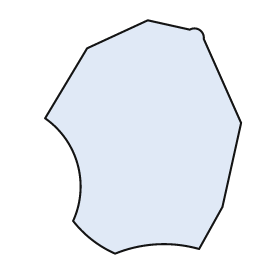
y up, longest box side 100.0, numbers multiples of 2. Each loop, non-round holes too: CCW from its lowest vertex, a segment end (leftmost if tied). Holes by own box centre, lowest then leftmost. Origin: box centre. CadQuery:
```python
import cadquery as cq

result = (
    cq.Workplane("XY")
    .moveTo(-12.0, -50.0)
    .threePointArc((6.0, -46.0), (24.0, -48.0))
    .lineTo(34.0, -30.0)
    .lineTo(42.0, 6.0)
    .lineTo(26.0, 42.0)
    .threePointArc((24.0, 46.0), (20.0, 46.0))
    .lineTo(2.0, 50.0)
    .lineTo(-24.0, 38.0)
    .lineTo(-42.0, 8.0)
    .threePointArc((-28.0, -12.0), (-30.0, -36.0))
    .threePointArc((-22.0, -44.0), (-12.0, -50.0))
    .close()
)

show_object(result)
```